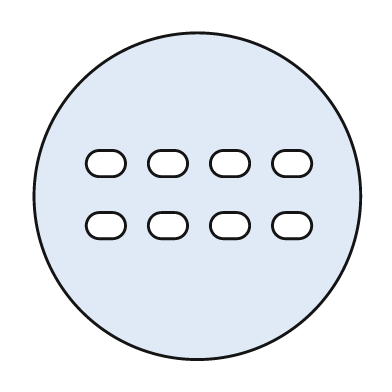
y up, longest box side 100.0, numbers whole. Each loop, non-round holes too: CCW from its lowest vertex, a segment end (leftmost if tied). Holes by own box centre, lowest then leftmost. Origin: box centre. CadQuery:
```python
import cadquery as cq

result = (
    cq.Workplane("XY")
    .moveTo(0.0, 0.0)
    .circle(50.0)
    .moveTo(-30.0, -13.0)
    .lineTo(-26.0, -13.0)
    .threePointArc((-22.0, -9.0), (-26.0, -5.0))
    .lineTo(-30.0, -5.0)
    .threePointArc((-34.0, -9.0), (-30.0, -13.0))
    .close()
    .moveTo(-11.0, -13.0)
    .lineTo(-7.0, -13.0)
    .threePointArc((-3.0, -9.0), (-7.0, -5.0))
    .lineTo(-11.0, -5.0)
    .threePointArc((-15.0, -9.0), (-11.0, -13.0))
    .close()
    .moveTo(8.0, -13.0)
    .lineTo(12.0, -13.0)
    .threePointArc((16.0, -9.0), (12.0, -5.0))
    .lineTo(8.0, -5.0)
    .threePointArc((4.0, -9.0), (8.0, -13.0))
    .close()
    .moveTo(27.0, -13.0)
    .lineTo(31.0, -13.0)
    .threePointArc((35.0, -9.0), (31.0, -5.0))
    .lineTo(27.0, -5.0)
    .threePointArc((23.0, -9.0), (27.0, -13.0))
    .close()
    .moveTo(-30.0, 6.0)
    .lineTo(-26.0, 6.0)
    .threePointArc((-22.0, 10.0), (-26.0, 14.0))
    .lineTo(-30.0, 14.0)
    .threePointArc((-34.0, 10.0), (-30.0, 6.0))
    .close()
    .moveTo(-11.0, 6.0)
    .lineTo(-7.0, 6.0)
    .threePointArc((-3.0, 10.0), (-7.0, 14.0))
    .lineTo(-11.0, 14.0)
    .threePointArc((-15.0, 10.0), (-11.0, 6.0))
    .close()
    .moveTo(8.0, 6.0)
    .lineTo(12.0, 6.0)
    .threePointArc((16.0, 10.0), (12.0, 14.0))
    .lineTo(8.0, 14.0)
    .threePointArc((4.0, 10.0), (8.0, 6.0))
    .close()
    .moveTo(27.0, 6.0)
    .lineTo(31.0, 6.0)
    .threePointArc((35.0, 10.0), (31.0, 14.0))
    .lineTo(27.0, 14.0)
    .threePointArc((23.0, 10.0), (27.0, 6.0))
    .close()
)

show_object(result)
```